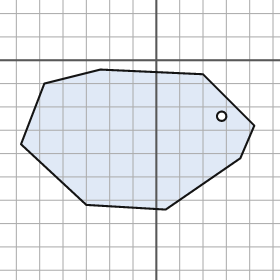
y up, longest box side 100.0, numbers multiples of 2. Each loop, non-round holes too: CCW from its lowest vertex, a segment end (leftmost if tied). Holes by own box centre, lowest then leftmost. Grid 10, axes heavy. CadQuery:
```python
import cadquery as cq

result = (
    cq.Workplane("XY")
    .moveTo(4.0, -64.0)
    .lineTo(36.0, -42.0)
    .lineTo(42.0, -28.0)
    .lineTo(20.0, -6.0)
    .lineTo(-24.0, -4.0)
    .lineTo(-48.0, -10.0)
    .lineTo(-58.0, -36.0)
    .lineTo(-30.0, -62.0)
    .close()
    .moveTo(28.0, -24.0)
    .circle(2.0)
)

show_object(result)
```